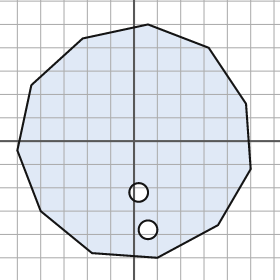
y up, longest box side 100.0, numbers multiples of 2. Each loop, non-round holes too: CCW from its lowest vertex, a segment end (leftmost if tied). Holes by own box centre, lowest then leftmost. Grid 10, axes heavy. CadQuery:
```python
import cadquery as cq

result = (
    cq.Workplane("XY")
    .moveTo(10.0, -50.0)
    .lineTo(36.0, -36.0)
    .lineTo(50.0, -12.0)
    .lineTo(48.0, 16.0)
    .lineTo(32.0, 40.0)
    .lineTo(6.0, 50.0)
    .lineTo(-22.0, 44.0)
    .lineTo(-44.0, 24.0)
    .lineTo(-50.0, -4.0)
    .lineTo(-40.0, -30.0)
    .lineTo(-18.0, -48.0)
    .close()
    .moveTo(6.0, -38.0)
    .circle(4.0)
    .moveTo(2.0, -22.0)
    .circle(4.0)
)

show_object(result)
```